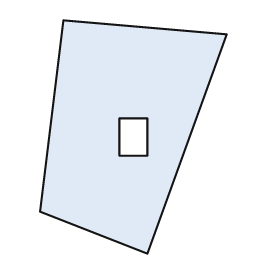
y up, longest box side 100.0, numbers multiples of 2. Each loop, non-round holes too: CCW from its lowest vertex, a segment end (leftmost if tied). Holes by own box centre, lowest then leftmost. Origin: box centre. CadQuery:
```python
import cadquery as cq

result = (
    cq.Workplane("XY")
    .moveTo(6.0, -50.0)
    .lineTo(40.0, 44.0)
    .lineTo(-30.0, 50.0)
    .lineTo(-40.0, -32.0)
    .close()
    .moveTo(-6.0, -8.0)
    .lineTo(6.0, -8.0)
    .lineTo(6.0, 8.0)
    .lineTo(-6.0, 8.0)
    .close()
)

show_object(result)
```